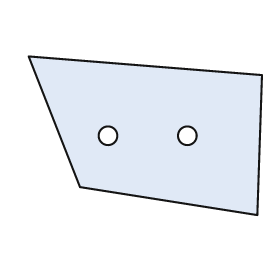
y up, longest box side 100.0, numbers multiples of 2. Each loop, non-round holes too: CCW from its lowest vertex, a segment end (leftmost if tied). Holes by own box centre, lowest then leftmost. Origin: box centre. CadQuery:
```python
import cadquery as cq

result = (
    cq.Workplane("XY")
    .moveTo(48.0, -34.0)
    .lineTo(50.0, 26.0)
    .lineTo(-50.0, 34.0)
    .lineTo(-28.0, -22.0)
    .close()
    .moveTo(-16.0, 0.0)
    .circle(4.0)
    .moveTo(18.0, 0.0)
    .circle(4.0)
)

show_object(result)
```